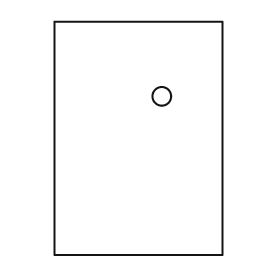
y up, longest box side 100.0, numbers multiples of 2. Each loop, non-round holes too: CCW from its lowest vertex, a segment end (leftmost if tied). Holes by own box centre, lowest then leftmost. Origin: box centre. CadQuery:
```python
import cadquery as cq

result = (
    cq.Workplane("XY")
    .moveTo(-36.0, -50.0)
    .lineTo(36.0, -50.0)
    .lineTo(36.0, 50.0)
    .lineTo(-36.0, 50.0)
    .close()
    .moveTo(10.0, 18.0)
    .circle(4.0)
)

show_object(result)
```